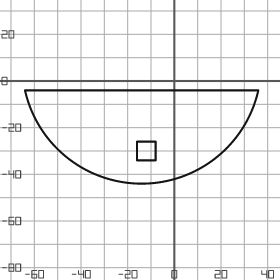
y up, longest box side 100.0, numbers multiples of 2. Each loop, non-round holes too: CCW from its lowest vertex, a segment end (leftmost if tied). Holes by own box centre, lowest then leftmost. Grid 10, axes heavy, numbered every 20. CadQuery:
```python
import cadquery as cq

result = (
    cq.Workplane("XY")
    .moveTo(-64.0, -4.0)
    .threePointArc((-14.0, -44.0), (36.0, -4.0))
    .close()
    .moveTo(-16.0, -34.0)
    .lineTo(-8.0, -34.0)
    .lineTo(-8.0, -26.0)
    .lineTo(-16.0, -26.0)
    .close()
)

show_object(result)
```